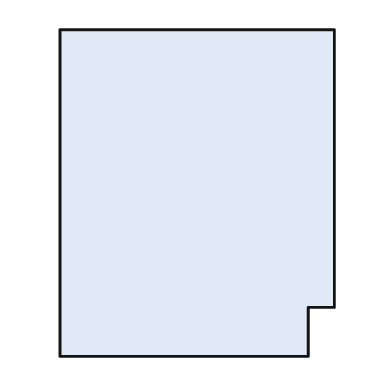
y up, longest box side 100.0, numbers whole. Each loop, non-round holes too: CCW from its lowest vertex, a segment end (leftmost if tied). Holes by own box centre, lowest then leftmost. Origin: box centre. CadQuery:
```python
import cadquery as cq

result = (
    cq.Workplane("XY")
    .moveTo(-42.0, -50.0)
    .lineTo(34.0, -50.0)
    .lineTo(34.0, -35.0)
    .lineTo(42.0, -35.0)
    .lineTo(42.0, 50.0)
    .lineTo(-42.0, 50.0)
    .close()
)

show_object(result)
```